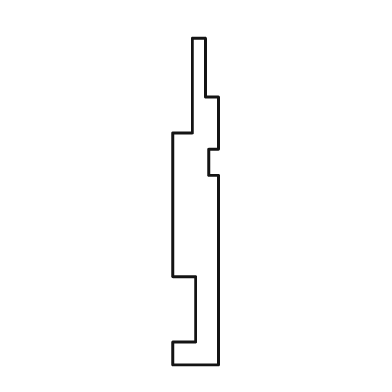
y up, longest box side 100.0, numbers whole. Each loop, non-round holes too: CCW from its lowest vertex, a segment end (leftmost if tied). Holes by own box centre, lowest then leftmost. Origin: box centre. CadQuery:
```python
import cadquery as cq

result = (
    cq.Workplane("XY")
    .moveTo(-7.0, -50.0)
    .lineTo(7.0, -50.0)
    .lineTo(7.0, 8.0)
    .lineTo(4.0, 8.0)
    .lineTo(4.0, 16.0)
    .lineTo(7.0, 16.0)
    .lineTo(7.0, 32.0)
    .lineTo(3.0, 32.0)
    .lineTo(3.0, 50.0)
    .lineTo(-1.0, 50.0)
    .lineTo(-1.0, 21.0)
    .lineTo(-7.0, 21.0)
    .lineTo(-7.0, -23.0)
    .lineTo(0.0, -23.0)
    .lineTo(0.0, -43.0)
    .lineTo(-7.0, -43.0)
    .close()
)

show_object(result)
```